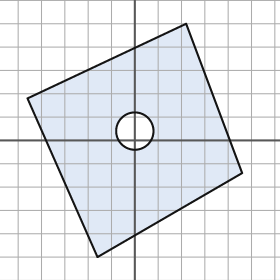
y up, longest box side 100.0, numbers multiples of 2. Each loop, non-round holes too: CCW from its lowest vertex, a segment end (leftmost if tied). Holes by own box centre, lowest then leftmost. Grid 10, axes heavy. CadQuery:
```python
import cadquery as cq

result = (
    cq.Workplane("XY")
    .moveTo(-16.0, -50.0)
    .lineTo(46.0, -14.0)
    .lineTo(22.0, 50.0)
    .lineTo(-46.0, 18.0)
    .close()
    .moveTo(0.0, 4.0)
    .circle(8.0)
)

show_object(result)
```